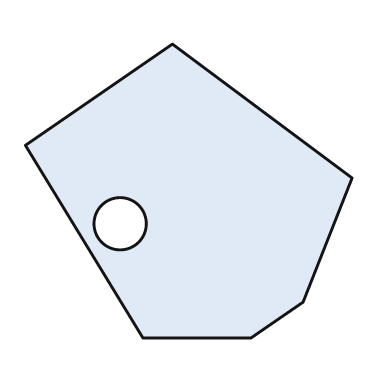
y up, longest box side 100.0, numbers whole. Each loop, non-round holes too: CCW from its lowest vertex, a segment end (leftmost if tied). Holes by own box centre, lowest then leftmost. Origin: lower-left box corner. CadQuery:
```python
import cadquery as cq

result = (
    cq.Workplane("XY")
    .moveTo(36.0, 0.0)
    .lineTo(69.0, 0.0)
    .lineTo(85.0, 11.0)
    .lineTo(100.0, 49.0)
    .lineTo(45.0, 90.0)
    .lineTo(0.0, 59.0)
    .close()
    .moveTo(29.0, 35.0)
    .circle(8.0)
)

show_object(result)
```